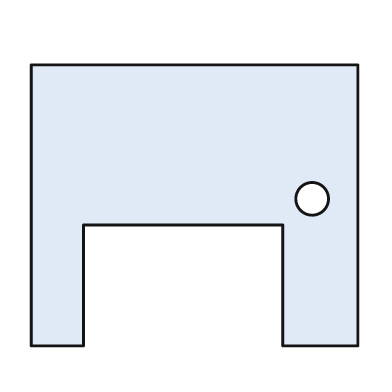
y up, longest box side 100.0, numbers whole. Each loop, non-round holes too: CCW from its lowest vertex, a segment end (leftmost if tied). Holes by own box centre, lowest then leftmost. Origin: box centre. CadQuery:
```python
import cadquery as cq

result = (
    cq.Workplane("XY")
    .moveTo(-50.0, -43.0)
    .lineTo(-34.0, -43.0)
    .lineTo(-34.0, -6.0)
    .lineTo(27.0, -6.0)
    .lineTo(27.0, -43.0)
    .lineTo(50.0, -43.0)
    .lineTo(50.0, 43.0)
    .lineTo(-50.0, 43.0)
    .close()
    .moveTo(36.0, 2.0)
    .circle(5.0)
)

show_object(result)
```